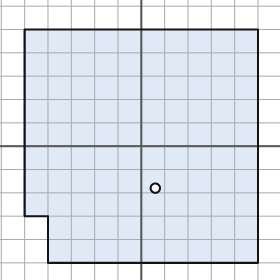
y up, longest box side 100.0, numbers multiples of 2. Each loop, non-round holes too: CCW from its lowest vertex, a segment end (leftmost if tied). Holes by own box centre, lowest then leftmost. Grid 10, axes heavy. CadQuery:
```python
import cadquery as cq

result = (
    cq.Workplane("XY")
    .moveTo(-40.0, -50.0)
    .lineTo(50.0, -50.0)
    .lineTo(50.0, 50.0)
    .lineTo(-50.0, 50.0)
    .lineTo(-50.0, -30.0)
    .lineTo(-40.0, -30.0)
    .close()
    .moveTo(6.0, -18.0)
    .circle(2.0)
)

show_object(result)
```